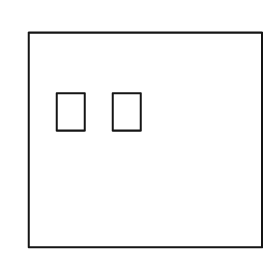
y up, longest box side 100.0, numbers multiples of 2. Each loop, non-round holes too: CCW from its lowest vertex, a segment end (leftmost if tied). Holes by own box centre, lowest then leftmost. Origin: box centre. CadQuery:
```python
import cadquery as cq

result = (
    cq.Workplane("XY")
    .moveTo(-50.0, -46.0)
    .lineTo(50.0, -46.0)
    .lineTo(50.0, 46.0)
    .lineTo(-50.0, 46.0)
    .close()
    .moveTo(-38.0, 4.0)
    .lineTo(-26.0, 4.0)
    .lineTo(-26.0, 20.0)
    .lineTo(-38.0, 20.0)
    .close()
    .moveTo(-14.0, 4.0)
    .lineTo(-2.0, 4.0)
    .lineTo(-2.0, 20.0)
    .lineTo(-14.0, 20.0)
    .close()
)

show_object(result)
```